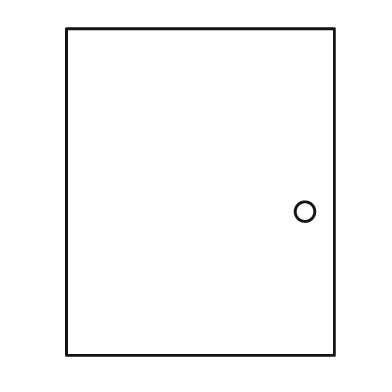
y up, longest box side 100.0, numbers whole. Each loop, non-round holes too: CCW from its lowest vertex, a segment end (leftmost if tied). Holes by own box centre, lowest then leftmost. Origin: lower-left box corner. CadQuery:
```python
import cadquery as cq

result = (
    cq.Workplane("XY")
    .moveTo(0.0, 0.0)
    .lineTo(82.0, 0.0)
    .lineTo(82.0, 100.0)
    .lineTo(0.0, 100.0)
    .close()
    .moveTo(73.0, 44.0)
    .circle(3.0)
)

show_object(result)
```